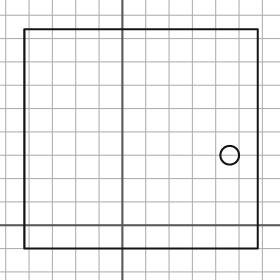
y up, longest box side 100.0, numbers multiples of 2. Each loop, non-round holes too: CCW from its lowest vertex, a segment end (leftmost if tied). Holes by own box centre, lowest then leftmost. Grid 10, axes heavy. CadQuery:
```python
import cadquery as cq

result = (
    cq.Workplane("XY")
    .moveTo(-42.0, -10.0)
    .lineTo(58.0, -10.0)
    .lineTo(58.0, 84.0)
    .lineTo(-42.0, 84.0)
    .close()
    .moveTo(46.0, 30.0)
    .circle(4.0)
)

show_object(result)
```